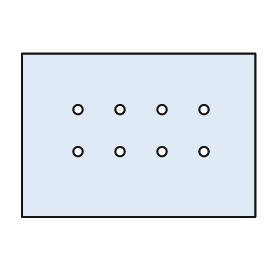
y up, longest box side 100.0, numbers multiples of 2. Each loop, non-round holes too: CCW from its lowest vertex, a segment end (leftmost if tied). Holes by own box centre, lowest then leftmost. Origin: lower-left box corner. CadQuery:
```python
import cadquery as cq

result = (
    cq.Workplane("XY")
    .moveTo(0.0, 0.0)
    .lineTo(100.0, 0.0)
    .lineTo(100.0, 70.0)
    .lineTo(0.0, 70.0)
    .close()
    .moveTo(24.0, 28.0)
    .circle(2.0)
    .moveTo(42.0, 28.0)
    .circle(2.0)
    .moveTo(60.0, 28.0)
    .circle(2.0)
    .moveTo(78.0, 28.0)
    .circle(2.0)
    .moveTo(24.0, 46.0)
    .circle(2.0)
    .moveTo(42.0, 46.0)
    .circle(2.0)
    .moveTo(60.0, 46.0)
    .circle(2.0)
    .moveTo(78.0, 46.0)
    .circle(2.0)
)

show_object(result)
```